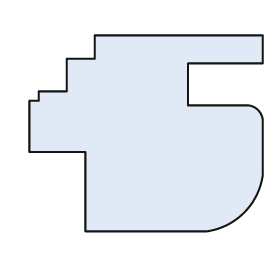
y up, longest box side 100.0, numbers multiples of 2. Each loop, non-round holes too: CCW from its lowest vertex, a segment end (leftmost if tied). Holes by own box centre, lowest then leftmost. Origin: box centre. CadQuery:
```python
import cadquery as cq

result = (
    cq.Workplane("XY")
    .moveTo(-26.0, -42.0)
    .lineTo(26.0, -42.0)
    .threePointArc((42.0, -34.0), (50.0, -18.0))
    .lineTo(50.0, 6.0)
    .threePointArc((48.0, 10.0), (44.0, 12.0))
    .lineTo(18.0, 12.0)
    .lineTo(18.0, 30.0)
    .lineTo(50.0, 30.0)
    .lineTo(50.0, 42.0)
    .lineTo(-22.0, 42.0)
    .lineTo(-22.0, 32.0)
    .lineTo(-34.0, 32.0)
    .lineTo(-34.0, 18.0)
    .lineTo(-46.0, 18.0)
    .lineTo(-46.0, 14.0)
    .lineTo(-50.0, 14.0)
    .lineTo(-50.0, -8.0)
    .lineTo(-26.0, -8.0)
    .close()
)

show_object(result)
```